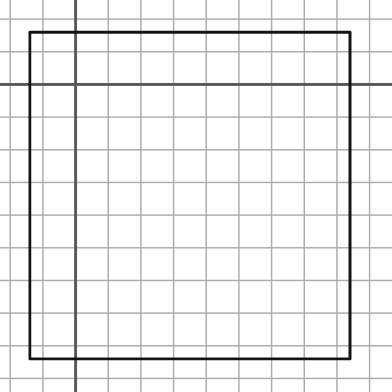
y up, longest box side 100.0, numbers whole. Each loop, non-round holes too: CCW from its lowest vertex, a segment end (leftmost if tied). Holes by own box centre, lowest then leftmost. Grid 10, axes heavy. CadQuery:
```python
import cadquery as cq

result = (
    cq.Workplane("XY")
    .moveTo(-14.0, -84.0)
    .lineTo(84.0, -84.0)
    .lineTo(84.0, 16.0)
    .lineTo(-14.0, 16.0)
    .close()
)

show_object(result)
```